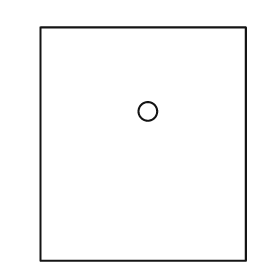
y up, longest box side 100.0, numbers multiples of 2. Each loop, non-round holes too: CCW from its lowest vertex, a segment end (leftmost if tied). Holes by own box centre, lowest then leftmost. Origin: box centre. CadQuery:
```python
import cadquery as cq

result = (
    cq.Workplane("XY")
    .moveTo(-44.0, -50.0)
    .lineTo(44.0, -50.0)
    .lineTo(44.0, 50.0)
    .lineTo(-44.0, 50.0)
    .close()
    .moveTo(2.0, 14.0)
    .circle(4.0)
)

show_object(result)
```